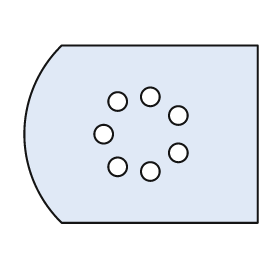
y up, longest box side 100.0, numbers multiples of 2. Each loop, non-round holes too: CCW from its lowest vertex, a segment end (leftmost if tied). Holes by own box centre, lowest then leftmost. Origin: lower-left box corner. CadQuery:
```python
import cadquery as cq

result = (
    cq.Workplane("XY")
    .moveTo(16.0, 0.0)
    .lineTo(100.0, 0.0)
    .lineTo(100.0, 76.0)
    .lineTo(16.0, 76.0)
    .threePointArc((0.0, 38.0), (16.0, 0.0))
    .close()
    .moveTo(54.0, 22.0)
    .circle(4.0)
    .moveTo(40.0, 24.0)
    .circle(4.0)
    .moveTo(66.0, 30.0)
    .circle(4.0)
    .moveTo(34.0, 38.0)
    .circle(4.0)
    .moveTo(66.0, 46.0)
    .circle(4.0)
    .moveTo(40.0, 52.0)
    .circle(4.0)
    .moveTo(54.0, 54.0)
    .circle(4.0)
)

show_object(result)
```